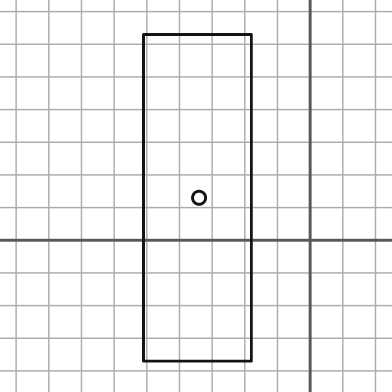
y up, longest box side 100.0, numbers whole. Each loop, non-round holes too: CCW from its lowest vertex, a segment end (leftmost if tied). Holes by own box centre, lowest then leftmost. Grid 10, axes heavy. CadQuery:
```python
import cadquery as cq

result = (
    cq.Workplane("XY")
    .moveTo(-51.0, -37.0)
    .lineTo(-18.0, -37.0)
    .lineTo(-18.0, 63.0)
    .lineTo(-51.0, 63.0)
    .close()
    .moveTo(-34.0, 13.0)
    .circle(2.0)
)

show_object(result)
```